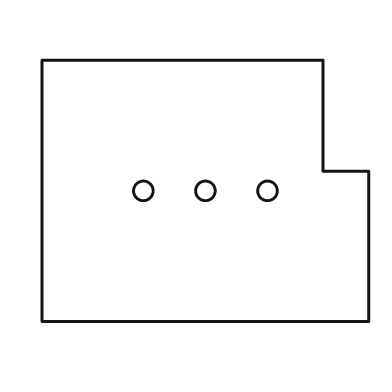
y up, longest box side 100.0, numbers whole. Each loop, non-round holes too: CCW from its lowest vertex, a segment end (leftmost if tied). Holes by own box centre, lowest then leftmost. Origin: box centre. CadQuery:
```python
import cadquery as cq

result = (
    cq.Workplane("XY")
    .moveTo(-50.0, -40.0)
    .lineTo(50.0, -40.0)
    .lineTo(50.0, 6.0)
    .lineTo(36.0, 6.0)
    .lineTo(36.0, 40.0)
    .lineTo(-50.0, 40.0)
    .close()
    .moveTo(-19.0, 0.0)
    .circle(3.0)
    .moveTo(0.0, 0.0)
    .circle(3.0)
    .moveTo(19.0, 0.0)
    .circle(3.0)
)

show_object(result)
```